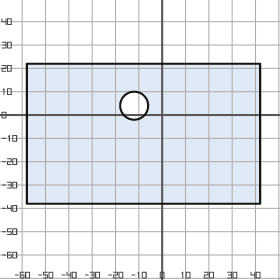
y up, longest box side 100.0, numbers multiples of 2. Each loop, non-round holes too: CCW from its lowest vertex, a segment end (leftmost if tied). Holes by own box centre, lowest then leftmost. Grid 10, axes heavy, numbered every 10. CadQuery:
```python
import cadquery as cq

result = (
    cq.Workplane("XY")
    .moveTo(-58.0, -38.0)
    .lineTo(42.0, -38.0)
    .lineTo(42.0, 22.0)
    .lineTo(-58.0, 22.0)
    .close()
    .moveTo(-12.0, 4.0)
    .circle(6.0)
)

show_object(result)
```